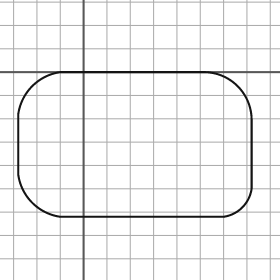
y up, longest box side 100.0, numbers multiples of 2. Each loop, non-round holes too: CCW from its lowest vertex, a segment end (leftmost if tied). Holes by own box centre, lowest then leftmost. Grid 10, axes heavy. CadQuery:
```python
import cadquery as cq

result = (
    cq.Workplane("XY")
    .moveTo(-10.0, -62.0)
    .lineTo(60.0, -62.0)
    .threePointArc((68.0, -58.0), (72.0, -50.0))
    .lineTo(72.0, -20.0)
    .threePointArc((66.0, -6.0), (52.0, 0.0))
    .lineTo(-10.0, 0.0)
    .threePointArc((-22.0, -6.0), (-28.0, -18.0))
    .lineTo(-28.0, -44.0)
    .threePointArc((-22.0, -56.0), (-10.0, -62.0))
    .close()
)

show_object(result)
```